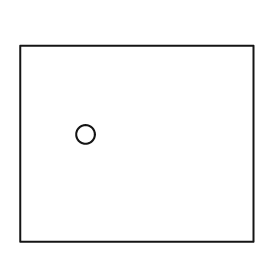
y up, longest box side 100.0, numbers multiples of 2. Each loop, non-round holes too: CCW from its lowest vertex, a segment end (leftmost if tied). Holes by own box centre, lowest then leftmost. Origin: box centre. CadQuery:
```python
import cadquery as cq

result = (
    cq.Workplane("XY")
    .moveTo(-50.0, -42.0)
    .lineTo(50.0, -42.0)
    .lineTo(50.0, 42.0)
    .lineTo(-50.0, 42.0)
    .close()
    .moveTo(-22.0, 4.0)
    .circle(4.0)
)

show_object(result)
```